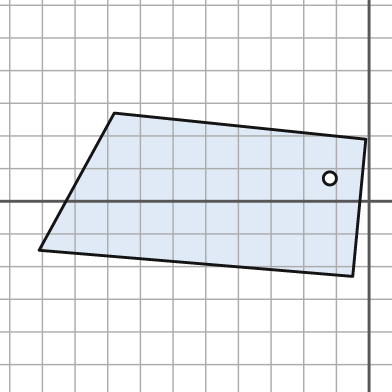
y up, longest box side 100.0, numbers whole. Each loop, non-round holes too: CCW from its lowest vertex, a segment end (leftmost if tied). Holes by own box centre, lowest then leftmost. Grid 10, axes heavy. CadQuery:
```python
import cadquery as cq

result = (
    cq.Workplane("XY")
    .moveTo(-5.0, -23.0)
    .lineTo(-1.0, 19.0)
    .lineTo(-78.0, 27.0)
    .lineTo(-101.0, -15.0)
    .close()
    .moveTo(-12.0, 7.0)
    .circle(2.0)
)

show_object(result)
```